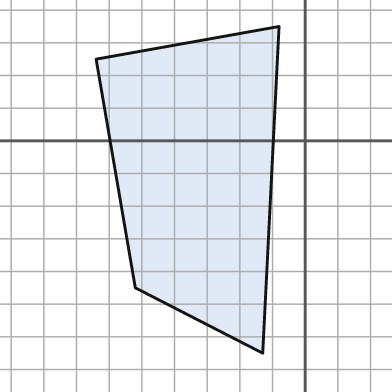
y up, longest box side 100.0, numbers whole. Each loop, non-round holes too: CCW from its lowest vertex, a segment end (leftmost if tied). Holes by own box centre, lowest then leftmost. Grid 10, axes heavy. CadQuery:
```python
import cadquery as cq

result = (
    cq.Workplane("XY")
    .moveTo(-13.0, -65.0)
    .lineTo(-8.0, 35.0)
    .lineTo(-64.0, 25.0)
    .lineTo(-52.0, -45.0)
    .close()
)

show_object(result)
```